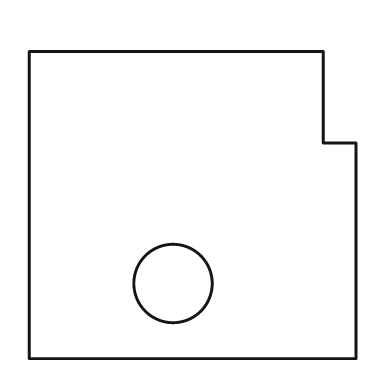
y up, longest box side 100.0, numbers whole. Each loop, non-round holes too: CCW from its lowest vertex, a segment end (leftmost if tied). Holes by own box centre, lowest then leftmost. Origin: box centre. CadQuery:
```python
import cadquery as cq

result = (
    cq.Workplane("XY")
    .moveTo(-50.0, -47.0)
    .lineTo(50.0, -47.0)
    .lineTo(50.0, 19.0)
    .lineTo(40.0, 19.0)
    .lineTo(40.0, 47.0)
    .lineTo(-50.0, 47.0)
    .close()
    .moveTo(-6.0, -24.0)
    .circle(12.0)
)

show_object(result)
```